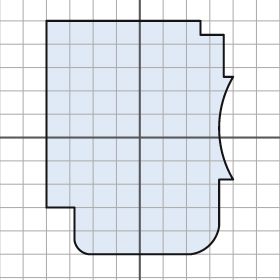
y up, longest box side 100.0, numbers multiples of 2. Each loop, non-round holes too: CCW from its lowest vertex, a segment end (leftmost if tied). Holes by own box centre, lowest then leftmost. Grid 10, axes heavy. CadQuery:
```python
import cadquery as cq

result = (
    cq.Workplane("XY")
    .moveTo(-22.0, -50.0)
    .lineTo(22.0, -50.0)
    .threePointArc((30.0, -46.0), (34.0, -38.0))
    .lineTo(34.0, -18.0)
    .lineTo(40.0, -18.0)
    .threePointArc((34.0, 4.0), (40.0, 26.0))
    .lineTo(36.0, 26.0)
    .lineTo(36.0, 44.0)
    .lineTo(26.0, 44.0)
    .lineTo(26.0, 50.0)
    .lineTo(-40.0, 50.0)
    .lineTo(-40.0, -30.0)
    .lineTo(-28.0, -30.0)
    .lineTo(-28.0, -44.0)
    .threePointArc((-26.0, -48.0), (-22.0, -50.0))
    .close()
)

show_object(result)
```